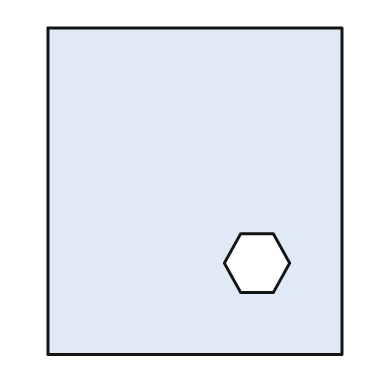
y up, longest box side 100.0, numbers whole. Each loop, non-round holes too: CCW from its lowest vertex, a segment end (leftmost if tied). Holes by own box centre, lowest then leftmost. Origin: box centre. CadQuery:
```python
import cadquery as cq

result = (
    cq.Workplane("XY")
    .moveTo(-45.0, -50.0)
    .lineTo(45.0, -50.0)
    .lineTo(45.0, 50.0)
    .lineTo(-45.0, 50.0)
    .close()
    .moveTo(14.0, -31.0)
    .lineTo(24.0, -31.0)
    .lineTo(29.0, -22.0)
    .lineTo(24.0, -13.0)
    .lineTo(14.0, -13.0)
    .lineTo(9.0, -22.0)
    .close()
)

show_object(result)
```